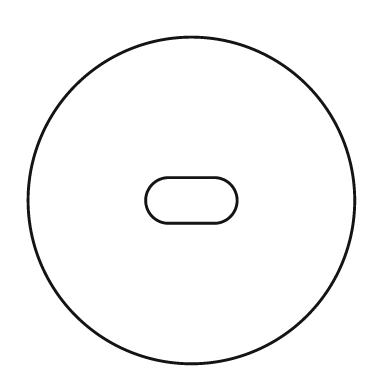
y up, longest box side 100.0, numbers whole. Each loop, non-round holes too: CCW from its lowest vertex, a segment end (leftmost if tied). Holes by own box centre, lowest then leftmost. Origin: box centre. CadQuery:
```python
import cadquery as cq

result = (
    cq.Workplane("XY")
    .moveTo(0.0, 0.0)
    .circle(50.0)
    .moveTo(-7.0, -7.0)
    .lineTo(7.0, -7.0)
    .threePointArc((14.0, 0.0), (7.0, 7.0))
    .lineTo(-7.0, 7.0)
    .threePointArc((-14.0, 0.0), (-7.0, -7.0))
    .close()
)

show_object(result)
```